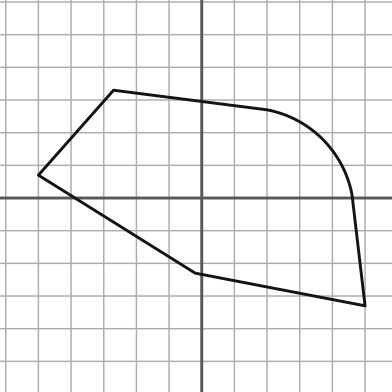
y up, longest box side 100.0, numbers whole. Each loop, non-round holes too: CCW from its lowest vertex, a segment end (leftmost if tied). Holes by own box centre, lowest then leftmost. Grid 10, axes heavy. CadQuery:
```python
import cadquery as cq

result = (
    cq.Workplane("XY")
    .moveTo(50.0, -33.0)
    .lineTo(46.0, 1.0)
    .threePointArc((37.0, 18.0), (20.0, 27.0))
    .lineTo(-27.0, 33.0)
    .lineTo(-50.0, 7.0)
    .lineTo(-2.0, -23.0)
    .close()
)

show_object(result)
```